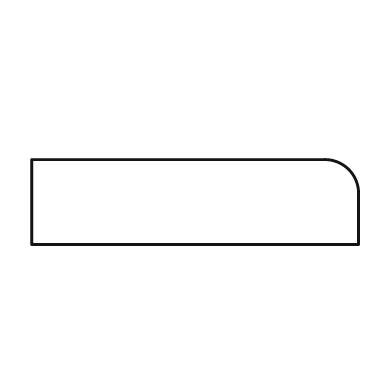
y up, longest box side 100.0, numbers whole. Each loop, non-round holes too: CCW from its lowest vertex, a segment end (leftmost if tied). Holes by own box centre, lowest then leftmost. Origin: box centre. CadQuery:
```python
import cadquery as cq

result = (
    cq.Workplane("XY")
    .moveTo(-50.0, -13.0)
    .lineTo(50.0, -13.0)
    .lineTo(50.0, 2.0)
    .threePointArc((47.0, 10.0), (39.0, 13.0))
    .lineTo(-50.0, 13.0)
    .close()
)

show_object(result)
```